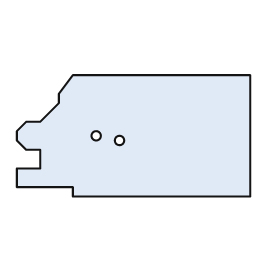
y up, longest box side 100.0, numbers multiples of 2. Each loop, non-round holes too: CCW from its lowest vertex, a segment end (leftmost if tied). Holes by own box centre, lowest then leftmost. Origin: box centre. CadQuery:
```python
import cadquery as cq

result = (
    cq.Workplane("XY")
    .moveTo(-26.0, -26.0)
    .lineTo(50.0, -26.0)
    .lineTo(50.0, 26.0)
    .lineTo(-26.0, 26.0)
    .lineTo(-32.0, 18.0)
    .lineTo(-32.0, 14.0)
    .lineTo(-40.0, 6.0)
    .lineTo(-46.0, 6.0)
    .lineTo(-50.0, 2.0)
    .lineTo(-50.0, -2.0)
    .lineTo(-46.0, -6.0)
    .lineTo(-40.0, -6.0)
    .lineTo(-40.0, -14.0)
    .lineTo(-50.0, -14.0)
    .lineTo(-50.0, -22.0)
    .lineTo(-26.0, -22.0)
    .close()
    .moveTo(-6.0, -2.0)
    .circle(2.0)
    .moveTo(-16.0, 0.0)
    .circle(2.0)
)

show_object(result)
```